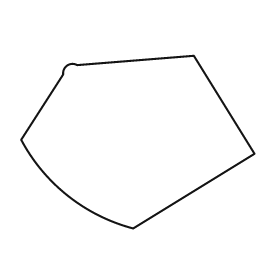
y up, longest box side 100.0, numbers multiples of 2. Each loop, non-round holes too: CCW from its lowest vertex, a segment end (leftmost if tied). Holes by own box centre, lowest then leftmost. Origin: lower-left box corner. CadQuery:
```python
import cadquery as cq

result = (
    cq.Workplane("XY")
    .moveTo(48.0, 0.0)
    .lineTo(100.0, 32.0)
    .lineTo(74.0, 74.0)
    .lineTo(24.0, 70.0)
    .threePointArc((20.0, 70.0), (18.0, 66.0))
    .lineTo(0.0, 38.0)
    .threePointArc((20.0, 14.0), (48.0, 0.0))
    .close()
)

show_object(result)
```